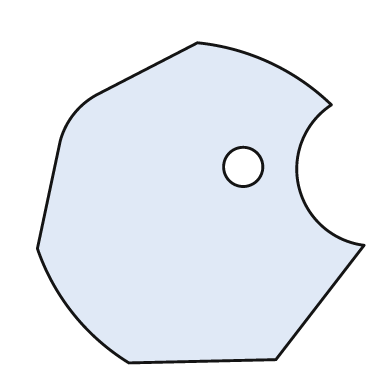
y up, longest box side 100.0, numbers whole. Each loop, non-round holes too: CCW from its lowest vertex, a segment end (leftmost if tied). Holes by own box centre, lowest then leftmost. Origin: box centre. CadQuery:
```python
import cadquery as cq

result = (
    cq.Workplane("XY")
    .moveTo(-22.0, -49.0)
    .lineTo(23.0, -48.0)
    .lineTo(50.0, -13.0)
    .threePointArc((30.0, 5.0), (40.0, 30.0))
    .threePointArc((21.0, 43.0), (-1.0, 49.0))
    .lineTo(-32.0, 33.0)
    .threePointArc((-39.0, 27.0), (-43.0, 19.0))
    .lineTo(-50.0, -14.0)
    .threePointArc((-39.0, -34.0), (-22.0, -49.0))
    .close()
    .moveTo(13.0, 11.0)
    .circle(6.0)
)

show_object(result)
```